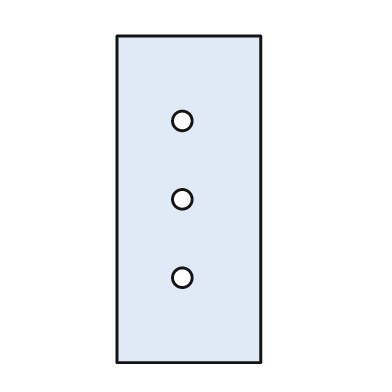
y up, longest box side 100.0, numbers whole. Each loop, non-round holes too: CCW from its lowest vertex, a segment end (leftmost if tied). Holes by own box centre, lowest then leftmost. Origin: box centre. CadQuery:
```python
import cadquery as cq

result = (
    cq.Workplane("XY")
    .moveTo(-22.0, -50.0)
    .lineTo(22.0, -50.0)
    .lineTo(22.0, 50.0)
    .lineTo(-22.0, 50.0)
    .close()
    .moveTo(-2.0, -24.0)
    .circle(3.0)
    .moveTo(-2.0, 0.0)
    .circle(3.0)
    .moveTo(-2.0, 24.0)
    .circle(3.0)
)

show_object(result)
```